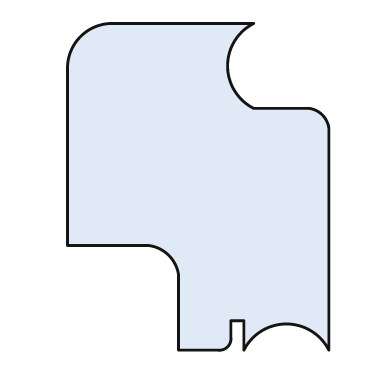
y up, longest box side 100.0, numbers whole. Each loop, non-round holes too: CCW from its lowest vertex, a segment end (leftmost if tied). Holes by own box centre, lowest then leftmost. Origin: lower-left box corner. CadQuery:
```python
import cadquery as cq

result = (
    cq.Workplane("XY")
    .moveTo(34.0, 0.0)
    .lineTo(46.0, 0.0)
    .threePointArc((49.0, 1.0), (50.0, 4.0))
    .lineTo(50.0, 9.0)
    .lineTo(54.0, 9.0)
    .lineTo(54.0, 0.0)
    .threePointArc((67.0, 8.0), (80.0, 0.0))
    .lineTo(80.0, 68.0)
    .threePointArc((78.0, 72.0), (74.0, 74.0))
    .lineTo(57.0, 74.0)
    .threePointArc((49.0, 87.0), (57.0, 100.0))
    .lineTo(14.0, 100.0)
    .threePointArc((4.0, 96.0), (0.0, 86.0))
    .lineTo(0.0, 32.0)
    .lineTo(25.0, 32.0)
    .threePointArc((31.0, 29.0), (34.0, 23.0))
    .close()
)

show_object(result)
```